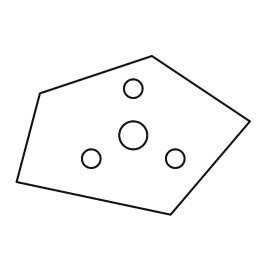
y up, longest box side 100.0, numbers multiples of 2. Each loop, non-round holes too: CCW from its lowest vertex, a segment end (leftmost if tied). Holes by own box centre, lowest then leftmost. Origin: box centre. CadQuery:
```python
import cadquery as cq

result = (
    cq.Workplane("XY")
    .moveTo(16.0, -34.0)
    .lineTo(50.0, 6.0)
    .lineTo(8.0, 34.0)
    .lineTo(-40.0, 18.0)
    .lineTo(-50.0, -20.0)
    .close()
    .moveTo(-18.0, -10.0)
    .circle(4.0)
    .moveTo(18.0, -10.0)
    .circle(4.0)
    .moveTo(0.0, 0.0)
    .circle(6.0)
    .moveTo(0.0, 20.0)
    .circle(4.0)
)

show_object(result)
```